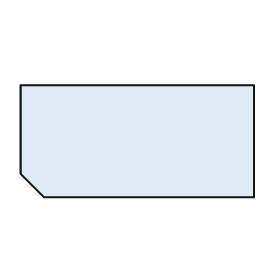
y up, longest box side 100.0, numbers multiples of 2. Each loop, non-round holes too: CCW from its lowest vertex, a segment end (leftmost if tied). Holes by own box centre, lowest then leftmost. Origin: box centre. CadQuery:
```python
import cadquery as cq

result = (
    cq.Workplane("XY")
    .moveTo(-40.0, -24.0)
    .lineTo(50.0, -24.0)
    .lineTo(50.0, 24.0)
    .lineTo(-50.0, 24.0)
    .lineTo(-50.0, -14.0)
    .close()
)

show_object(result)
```